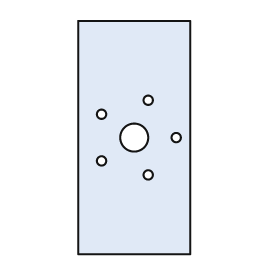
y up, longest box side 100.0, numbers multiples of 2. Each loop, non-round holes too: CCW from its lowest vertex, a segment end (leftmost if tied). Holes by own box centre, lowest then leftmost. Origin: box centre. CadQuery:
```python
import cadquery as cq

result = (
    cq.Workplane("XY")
    .moveTo(-24.0, -50.0)
    .lineTo(24.0, -50.0)
    .lineTo(24.0, 50.0)
    .lineTo(-24.0, 50.0)
    .close()
    .moveTo(6.0, -16.0)
    .circle(2.0)
    .moveTo(-14.0, -10.0)
    .circle(2.0)
    .moveTo(0.0, 0.0)
    .circle(6.0)
    .moveTo(18.0, 0.0)
    .circle(2.0)
    .moveTo(-14.0, 10.0)
    .circle(2.0)
    .moveTo(6.0, 16.0)
    .circle(2.0)
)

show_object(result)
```